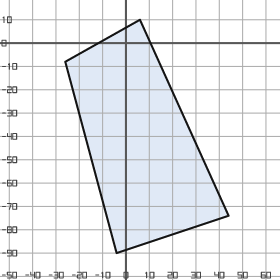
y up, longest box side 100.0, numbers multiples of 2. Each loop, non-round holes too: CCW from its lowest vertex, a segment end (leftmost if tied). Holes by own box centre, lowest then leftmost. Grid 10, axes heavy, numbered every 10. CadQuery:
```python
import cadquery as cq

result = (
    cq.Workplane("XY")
    .moveTo(-4.0, -90.0)
    .lineTo(44.0, -74.0)
    .lineTo(6.0, 10.0)
    .lineTo(-26.0, -8.0)
    .close()
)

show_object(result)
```